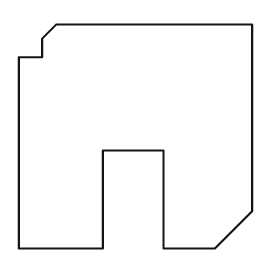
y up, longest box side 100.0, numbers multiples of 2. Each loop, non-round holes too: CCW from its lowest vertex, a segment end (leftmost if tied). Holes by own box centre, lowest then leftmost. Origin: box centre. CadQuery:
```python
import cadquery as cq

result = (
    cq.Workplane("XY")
    .moveTo(-50.0, -48.0)
    .lineTo(-14.0, -48.0)
    .lineTo(-14.0, -6.0)
    .lineTo(12.0, -6.0)
    .lineTo(12.0, -48.0)
    .lineTo(34.0, -48.0)
    .lineTo(50.0, -32.0)
    .lineTo(50.0, 48.0)
    .lineTo(-34.0, 48.0)
    .lineTo(-40.0, 42.0)
    .lineTo(-40.0, 34.0)
    .lineTo(-50.0, 34.0)
    .close()
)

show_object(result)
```